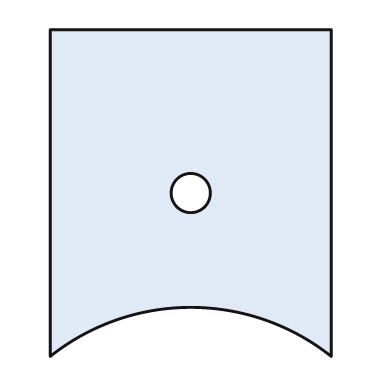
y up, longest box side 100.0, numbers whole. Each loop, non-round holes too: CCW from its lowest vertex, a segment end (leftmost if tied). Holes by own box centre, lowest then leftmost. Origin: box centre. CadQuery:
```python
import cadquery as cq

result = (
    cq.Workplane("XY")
    .moveTo(-43.0, -50.0)
    .threePointArc((0.0, -35.0), (43.0, -50.0))
    .lineTo(43.0, 50.0)
    .lineTo(-43.0, 50.0)
    .close()
    .moveTo(0.0, 0.0)
    .circle(6.0)
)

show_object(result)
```